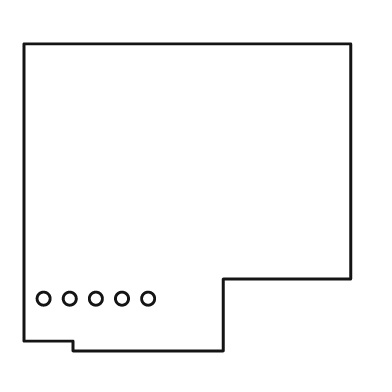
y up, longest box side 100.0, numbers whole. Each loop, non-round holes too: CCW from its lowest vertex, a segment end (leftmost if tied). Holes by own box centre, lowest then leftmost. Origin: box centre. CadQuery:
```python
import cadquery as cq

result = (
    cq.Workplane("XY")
    .moveTo(-35.0, -47.0)
    .lineTo(11.0, -47.0)
    .lineTo(11.0, -25.0)
    .lineTo(50.0, -25.0)
    .lineTo(50.0, 47.0)
    .lineTo(-50.0, 47.0)
    .lineTo(-50.0, -44.0)
    .lineTo(-35.0, -44.0)
    .close()
    .moveTo(-44.0, -31.0)
    .circle(2.0)
    .moveTo(-36.0, -31.0)
    .circle(2.0)
    .moveTo(-28.0, -31.0)
    .circle(2.0)
    .moveTo(-20.0, -31.0)
    .circle(2.0)
    .moveTo(-12.0, -31.0)
    .circle(2.0)
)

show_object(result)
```